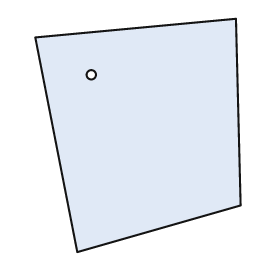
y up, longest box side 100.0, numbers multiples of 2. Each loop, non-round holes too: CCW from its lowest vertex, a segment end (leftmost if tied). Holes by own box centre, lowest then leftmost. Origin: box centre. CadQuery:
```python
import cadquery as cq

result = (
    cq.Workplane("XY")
    .moveTo(-26.0, -50.0)
    .lineTo(44.0, -30.0)
    .lineTo(42.0, 50.0)
    .lineTo(-44.0, 42.0)
    .close()
    .moveTo(-20.0, 26.0)
    .circle(2.0)
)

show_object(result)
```